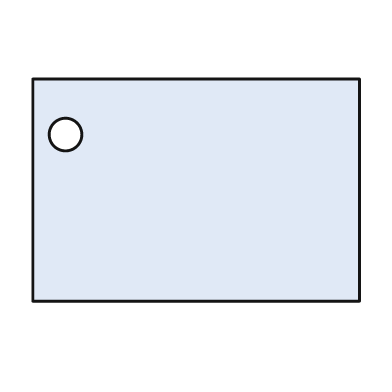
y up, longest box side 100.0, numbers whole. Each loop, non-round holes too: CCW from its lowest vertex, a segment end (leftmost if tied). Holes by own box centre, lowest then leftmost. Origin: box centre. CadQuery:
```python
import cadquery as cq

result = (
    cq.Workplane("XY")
    .moveTo(-50.0, -34.0)
    .lineTo(50.0, -34.0)
    .lineTo(50.0, 34.0)
    .lineTo(-50.0, 34.0)
    .close()
    .moveTo(-40.0, 17.0)
    .circle(5.0)
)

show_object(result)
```